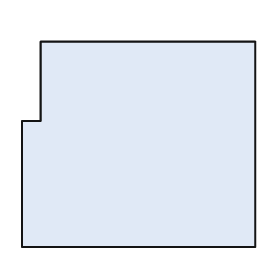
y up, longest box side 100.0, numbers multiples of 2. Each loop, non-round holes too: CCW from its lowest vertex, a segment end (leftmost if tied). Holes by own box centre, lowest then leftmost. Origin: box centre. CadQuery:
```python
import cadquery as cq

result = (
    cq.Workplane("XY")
    .moveTo(-50.0, -44.0)
    .lineTo(50.0, -44.0)
    .lineTo(50.0, 44.0)
    .lineTo(-42.0, 44.0)
    .lineTo(-42.0, 10.0)
    .lineTo(-50.0, 10.0)
    .close()
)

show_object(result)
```